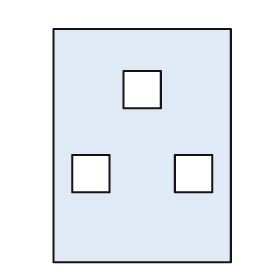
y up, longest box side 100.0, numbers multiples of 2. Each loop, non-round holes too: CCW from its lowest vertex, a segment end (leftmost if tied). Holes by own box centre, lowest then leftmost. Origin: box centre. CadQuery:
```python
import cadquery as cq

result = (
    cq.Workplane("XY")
    .moveTo(-38.0, -50.0)
    .lineTo(38.0, -50.0)
    .lineTo(38.0, 50.0)
    .lineTo(-38.0, 50.0)
    .close()
    .moveTo(-30.0, -20.0)
    .lineTo(-14.0, -20.0)
    .lineTo(-14.0, -4.0)
    .lineTo(-30.0, -4.0)
    .close()
    .moveTo(14.0, -20.0)
    .lineTo(30.0, -20.0)
    .lineTo(30.0, -4.0)
    .lineTo(14.0, -4.0)
    .close()
    .moveTo(-8.0, 16.0)
    .lineTo(8.0, 16.0)
    .lineTo(8.0, 32.0)
    .lineTo(-8.0, 32.0)
    .close()
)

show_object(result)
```